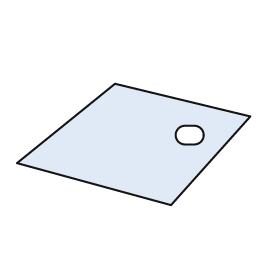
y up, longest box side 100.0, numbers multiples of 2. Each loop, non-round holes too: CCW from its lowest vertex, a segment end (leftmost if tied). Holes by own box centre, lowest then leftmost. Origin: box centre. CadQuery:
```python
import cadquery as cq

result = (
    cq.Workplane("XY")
    .moveTo(16.0, -26.0)
    .lineTo(50.0, 12.0)
    .lineTo(-8.0, 26.0)
    .lineTo(-50.0, -8.0)
    .close()
    .moveTo(22.0, 0.0)
    .lineTo(26.0, 0.0)
    .threePointArc((30.0, 4.0), (26.0, 8.0))
    .lineTo(22.0, 8.0)
    .threePointArc((18.0, 4.0), (22.0, 0.0))
    .close()
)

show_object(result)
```